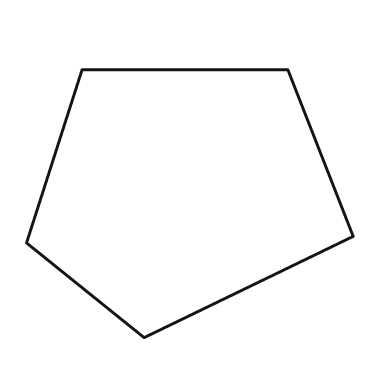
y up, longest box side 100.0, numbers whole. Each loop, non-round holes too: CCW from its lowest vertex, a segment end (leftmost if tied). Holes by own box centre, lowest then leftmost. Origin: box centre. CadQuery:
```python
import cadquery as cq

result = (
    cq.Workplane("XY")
    .moveTo(-14.0, -41.0)
    .lineTo(50.0, -10.0)
    .lineTo(30.0, 41.0)
    .lineTo(-33.0, 41.0)
    .lineTo(-50.0, -12.0)
    .close()
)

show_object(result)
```